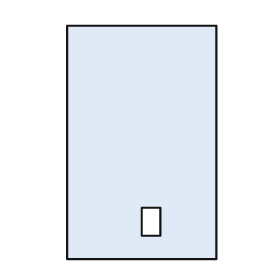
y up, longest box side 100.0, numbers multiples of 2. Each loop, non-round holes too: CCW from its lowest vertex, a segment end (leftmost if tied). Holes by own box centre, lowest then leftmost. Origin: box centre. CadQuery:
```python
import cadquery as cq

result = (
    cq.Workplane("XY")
    .moveTo(-32.0, -50.0)
    .lineTo(32.0, -50.0)
    .lineTo(32.0, 50.0)
    .lineTo(-32.0, 50.0)
    .close()
    .moveTo(0.0, -40.0)
    .lineTo(8.0, -40.0)
    .lineTo(8.0, -28.0)
    .lineTo(0.0, -28.0)
    .close()
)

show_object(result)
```